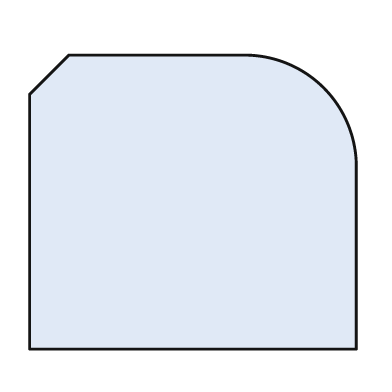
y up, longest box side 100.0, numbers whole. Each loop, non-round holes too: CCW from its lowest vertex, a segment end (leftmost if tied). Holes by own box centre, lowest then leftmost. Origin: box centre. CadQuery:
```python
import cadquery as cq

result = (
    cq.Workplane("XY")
    .moveTo(-50.0, -45.0)
    .lineTo(50.0, -45.0)
    .lineTo(50.0, 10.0)
    .threePointArc((40.0, 35.0), (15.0, 45.0))
    .lineTo(-38.0, 45.0)
    .lineTo(-50.0, 33.0)
    .close()
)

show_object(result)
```